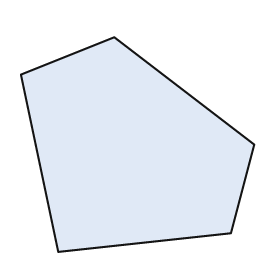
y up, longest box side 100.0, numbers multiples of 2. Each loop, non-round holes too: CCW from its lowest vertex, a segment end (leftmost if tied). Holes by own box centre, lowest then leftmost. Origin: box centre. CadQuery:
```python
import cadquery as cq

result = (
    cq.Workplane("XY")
    .moveTo(-34.0, -46.0)
    .lineTo(40.0, -38.0)
    .lineTo(50.0, 0.0)
    .lineTo(-10.0, 46.0)
    .lineTo(-50.0, 30.0)
    .close()
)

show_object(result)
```